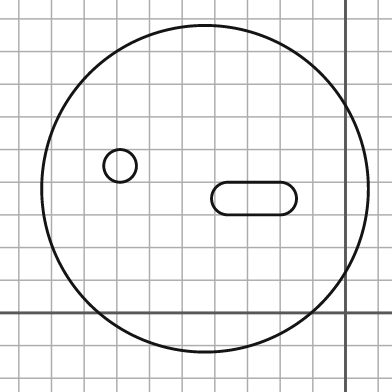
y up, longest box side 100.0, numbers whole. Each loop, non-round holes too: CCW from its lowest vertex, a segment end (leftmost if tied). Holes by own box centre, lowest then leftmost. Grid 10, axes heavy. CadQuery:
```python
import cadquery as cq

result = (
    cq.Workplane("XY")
    .moveTo(-43.0, 38.0)
    .circle(50.0)
    .moveTo(-36.0, 30.0)
    .lineTo(-20.0, 30.0)
    .threePointArc((-15.0, 35.0), (-20.0, 40.0))
    .lineTo(-36.0, 40.0)
    .threePointArc((-41.0, 35.0), (-36.0, 30.0))
    .close()
    .moveTo(-69.0, 45.0)
    .circle(5.0)
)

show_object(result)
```